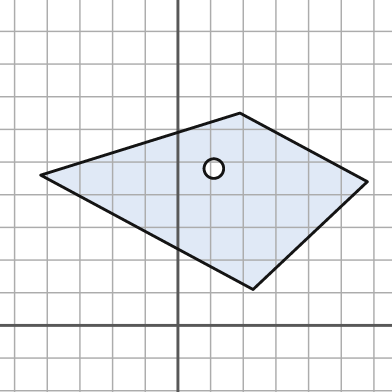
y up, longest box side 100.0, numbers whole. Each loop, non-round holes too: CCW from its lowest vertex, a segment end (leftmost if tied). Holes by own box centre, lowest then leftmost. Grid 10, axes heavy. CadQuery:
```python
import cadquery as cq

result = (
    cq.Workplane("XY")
    .moveTo(23.0, 11.0)
    .lineTo(58.0, 44.0)
    .lineTo(19.0, 65.0)
    .lineTo(-42.0, 46.0)
    .close()
    .moveTo(11.0, 48.0)
    .circle(3.0)
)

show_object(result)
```